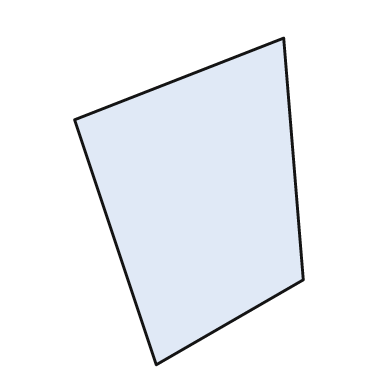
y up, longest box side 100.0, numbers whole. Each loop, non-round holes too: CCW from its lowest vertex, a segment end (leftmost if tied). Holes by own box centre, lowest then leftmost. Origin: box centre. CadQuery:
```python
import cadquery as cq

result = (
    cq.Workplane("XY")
    .moveTo(-10.0, -50.0)
    .lineTo(35.0, -24.0)
    .lineTo(29.0, 50.0)
    .lineTo(-35.0, 25.0)
    .close()
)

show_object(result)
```